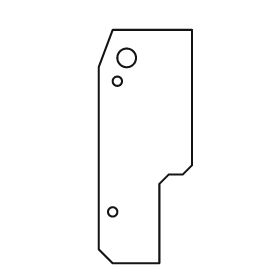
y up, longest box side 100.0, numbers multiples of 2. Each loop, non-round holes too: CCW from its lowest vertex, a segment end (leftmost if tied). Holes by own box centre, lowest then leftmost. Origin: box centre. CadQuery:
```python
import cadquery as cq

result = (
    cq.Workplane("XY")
    .moveTo(-14.0, -50.0)
    .lineTo(6.0, -50.0)
    .lineTo(6.0, -16.0)
    .lineTo(10.0, -12.0)
    .lineTo(16.0, -12.0)
    .lineTo(20.0, -8.0)
    .lineTo(20.0, 50.0)
    .lineTo(-14.0, 50.0)
    .lineTo(-20.0, 34.0)
    .lineTo(-20.0, -44.0)
    .close()
    .moveTo(-14.0, -28.0)
    .circle(2.0)
    .moveTo(-12.0, 28.0)
    .circle(2.0)
    .moveTo(-8.0, 38.0)
    .circle(4.0)
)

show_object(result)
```